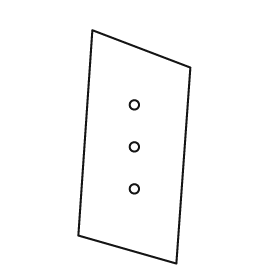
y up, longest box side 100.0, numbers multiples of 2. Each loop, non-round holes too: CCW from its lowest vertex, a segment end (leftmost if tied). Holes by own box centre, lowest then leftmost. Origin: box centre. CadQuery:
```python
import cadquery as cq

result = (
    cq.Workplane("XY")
    .moveTo(18.0, -50.0)
    .lineTo(24.0, 34.0)
    .lineTo(-18.0, 50.0)
    .lineTo(-24.0, -38.0)
    .close()
    .moveTo(0.0, -18.0)
    .circle(2.0)
    .moveTo(0.0, 0.0)
    .circle(2.0)
    .moveTo(0.0, 18.0)
    .circle(2.0)
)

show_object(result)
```